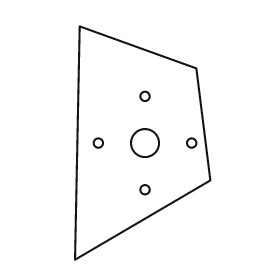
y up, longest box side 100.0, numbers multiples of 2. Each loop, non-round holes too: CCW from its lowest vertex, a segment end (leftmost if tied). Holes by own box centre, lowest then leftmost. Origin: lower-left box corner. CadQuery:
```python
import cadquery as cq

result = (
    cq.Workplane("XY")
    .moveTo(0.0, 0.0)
    .lineTo(58.0, 34.0)
    .lineTo(52.0, 82.0)
    .lineTo(2.0, 100.0)
    .close()
    .moveTo(30.0, 30.0)
    .circle(2.0)
    .moveTo(10.0, 50.0)
    .circle(2.0)
    .moveTo(30.0, 50.0)
    .circle(6.0)
    .moveTo(50.0, 50.0)
    .circle(2.0)
    .moveTo(30.0, 70.0)
    .circle(2.0)
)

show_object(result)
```